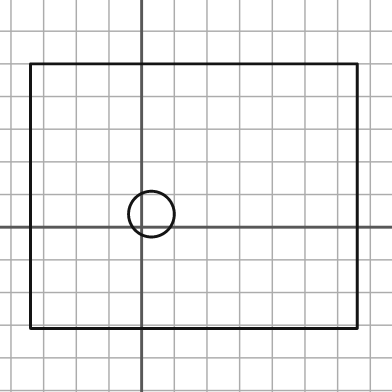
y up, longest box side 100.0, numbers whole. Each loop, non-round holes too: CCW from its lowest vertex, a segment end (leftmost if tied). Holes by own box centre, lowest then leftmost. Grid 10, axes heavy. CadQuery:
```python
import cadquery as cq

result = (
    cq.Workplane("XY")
    .moveTo(-34.0, -31.0)
    .lineTo(66.0, -31.0)
    .lineTo(66.0, 50.0)
    .lineTo(-34.0, 50.0)
    .close()
    .moveTo(3.0, 4.0)
    .circle(7.0)
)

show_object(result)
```